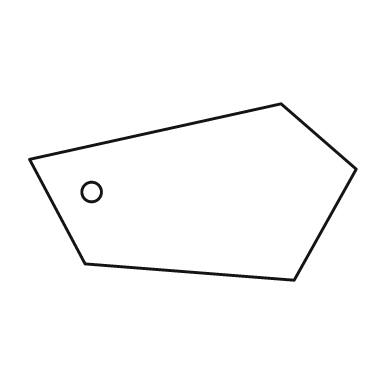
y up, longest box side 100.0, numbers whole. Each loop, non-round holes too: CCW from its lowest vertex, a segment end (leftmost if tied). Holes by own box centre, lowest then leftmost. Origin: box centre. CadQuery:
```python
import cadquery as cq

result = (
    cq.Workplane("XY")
    .moveTo(31.0, -27.0)
    .lineTo(50.0, 7.0)
    .lineTo(27.0, 27.0)
    .lineTo(-50.0, 10.0)
    .lineTo(-33.0, -22.0)
    .close()
    .moveTo(-31.0, 0.0)
    .circle(3.0)
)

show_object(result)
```